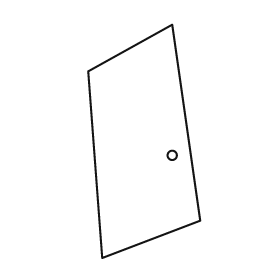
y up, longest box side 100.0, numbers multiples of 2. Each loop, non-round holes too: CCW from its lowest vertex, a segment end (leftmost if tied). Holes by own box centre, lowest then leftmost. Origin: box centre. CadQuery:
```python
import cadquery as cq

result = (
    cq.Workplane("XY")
    .moveTo(-18.0, -50.0)
    .lineTo(24.0, -34.0)
    .lineTo(12.0, 50.0)
    .lineTo(-24.0, 30.0)
    .close()
    .moveTo(12.0, -6.0)
    .circle(2.0)
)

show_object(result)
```